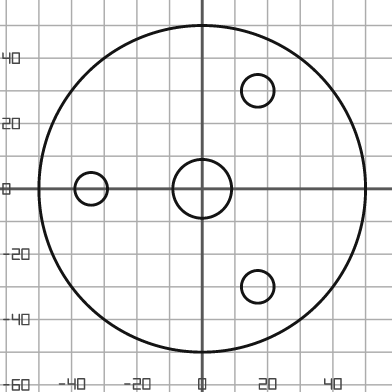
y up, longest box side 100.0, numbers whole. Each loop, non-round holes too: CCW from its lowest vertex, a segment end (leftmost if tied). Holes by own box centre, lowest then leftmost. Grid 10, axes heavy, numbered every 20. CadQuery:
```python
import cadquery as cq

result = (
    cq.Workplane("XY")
    .moveTo(0.0, 0.0)
    .circle(50.0)
    .moveTo(17.0, -30.0)
    .circle(5.0)
    .moveTo(-34.0, 0.0)
    .circle(5.0)
    .moveTo(0.0, 0.0)
    .circle(9.0)
    .moveTo(17.0, 30.0)
    .circle(5.0)
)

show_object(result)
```